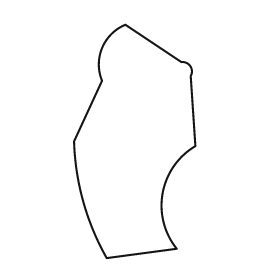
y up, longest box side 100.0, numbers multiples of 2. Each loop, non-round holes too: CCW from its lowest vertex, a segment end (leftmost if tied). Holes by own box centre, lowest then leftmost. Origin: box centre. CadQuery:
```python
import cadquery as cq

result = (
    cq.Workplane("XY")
    .moveTo(-12.0, -50.0)
    .lineTo(18.0, -46.0)
    .threePointArc((12.0, -22.0), (26.0, -2.0))
    .lineTo(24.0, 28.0)
    .threePointArc((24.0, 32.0), (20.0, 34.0))
    .lineTo(-4.0, 50.0)
    .threePointArc((-14.0, 40.0), (-14.0, 26.0))
    .lineTo(-26.0, 0.0)
    .threePointArc((-22.0, -26.0), (-12.0, -50.0))
    .close()
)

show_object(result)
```